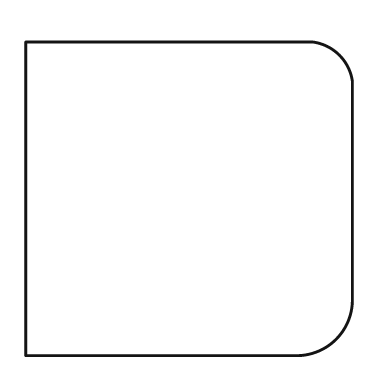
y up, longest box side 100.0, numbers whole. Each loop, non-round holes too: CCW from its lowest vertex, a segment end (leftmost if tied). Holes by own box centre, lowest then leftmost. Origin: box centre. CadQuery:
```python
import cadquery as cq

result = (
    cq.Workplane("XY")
    .moveTo(-50.0, -48.0)
    .lineTo(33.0, -48.0)
    .threePointArc((45.0, -43.0), (50.0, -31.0))
    .lineTo(50.0, 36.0)
    .threePointArc((46.0, 44.0), (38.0, 48.0))
    .lineTo(-50.0, 48.0)
    .close()
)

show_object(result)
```